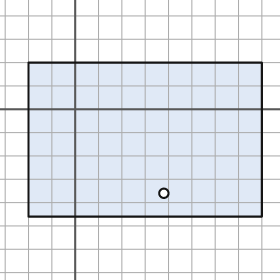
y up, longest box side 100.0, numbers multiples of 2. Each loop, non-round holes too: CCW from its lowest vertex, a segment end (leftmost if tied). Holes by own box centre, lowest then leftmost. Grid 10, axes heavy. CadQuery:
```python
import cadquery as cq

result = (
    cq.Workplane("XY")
    .moveTo(-20.0, -46.0)
    .lineTo(80.0, -46.0)
    .lineTo(80.0, 20.0)
    .lineTo(-20.0, 20.0)
    .close()
    .moveTo(38.0, -36.0)
    .circle(2.0)
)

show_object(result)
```